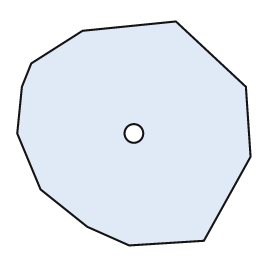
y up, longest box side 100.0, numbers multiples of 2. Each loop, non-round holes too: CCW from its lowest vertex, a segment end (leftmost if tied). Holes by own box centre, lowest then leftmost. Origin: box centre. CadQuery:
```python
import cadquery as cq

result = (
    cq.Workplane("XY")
    .moveTo(-2.0, -48.0)
    .lineTo(30.0, -46.0)
    .lineTo(50.0, -10.0)
    .lineTo(48.0, 20.0)
    .lineTo(18.0, 48.0)
    .lineTo(-22.0, 44.0)
    .lineTo(-44.0, 30.0)
    .lineTo(-48.0, 20.0)
    .lineTo(-50.0, 0.0)
    .lineTo(-40.0, -24.0)
    .lineTo(-20.0, -40.0)
    .close()
    .moveTo(0.0, 0.0)
    .circle(4.0)
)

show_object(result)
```